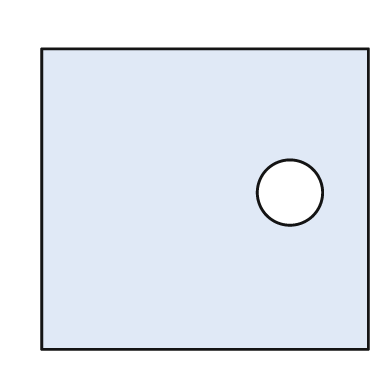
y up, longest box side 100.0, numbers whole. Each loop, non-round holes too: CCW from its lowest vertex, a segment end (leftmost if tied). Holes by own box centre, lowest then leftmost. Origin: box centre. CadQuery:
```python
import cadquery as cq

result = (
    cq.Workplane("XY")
    .moveTo(-50.0, -46.0)
    .lineTo(50.0, -46.0)
    .lineTo(50.0, 46.0)
    .lineTo(-50.0, 46.0)
    .close()
    .moveTo(26.0, 2.0)
    .circle(10.0)
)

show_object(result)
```